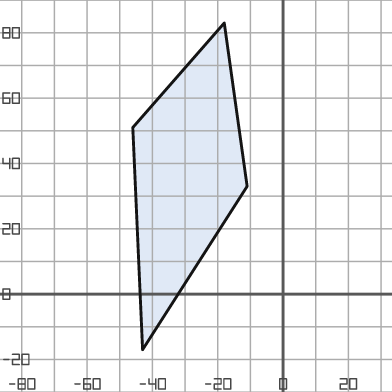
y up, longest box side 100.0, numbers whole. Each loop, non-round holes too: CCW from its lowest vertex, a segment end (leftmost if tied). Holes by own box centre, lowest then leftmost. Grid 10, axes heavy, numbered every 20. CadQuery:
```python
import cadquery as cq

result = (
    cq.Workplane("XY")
    .moveTo(-43.0, -17.0)
    .lineTo(-11.0, 33.0)
    .lineTo(-18.0, 83.0)
    .lineTo(-46.0, 51.0)
    .close()
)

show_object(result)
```